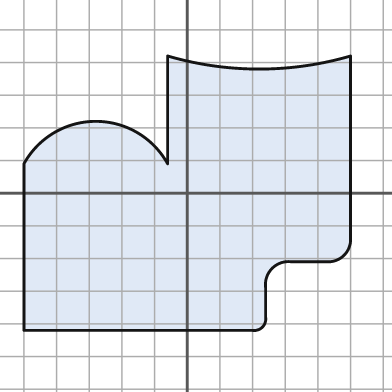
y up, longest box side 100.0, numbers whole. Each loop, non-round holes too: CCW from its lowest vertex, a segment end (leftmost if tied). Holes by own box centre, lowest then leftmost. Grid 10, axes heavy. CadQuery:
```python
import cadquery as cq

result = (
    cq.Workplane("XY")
    .moveTo(-50.0, -42.0)
    .lineTo(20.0, -42.0)
    .threePointArc((23.0, -41.0), (24.0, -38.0))
    .lineTo(24.0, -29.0)
    .threePointArc((26.0, -23.0), (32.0, -21.0))
    .lineTo(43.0, -21.0)
    .threePointArc((48.0, -19.0), (50.0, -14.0))
    .lineTo(50.0, 42.0)
    .threePointArc((22.0, 38.0), (-6.0, 42.0))
    .lineTo(-6.0, 9.0)
    .threePointArc((-28.0, 22.0), (-50.0, 9.0))
    .close()
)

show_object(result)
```